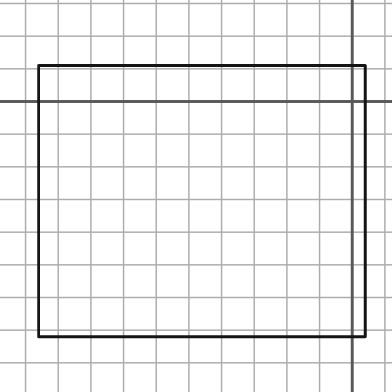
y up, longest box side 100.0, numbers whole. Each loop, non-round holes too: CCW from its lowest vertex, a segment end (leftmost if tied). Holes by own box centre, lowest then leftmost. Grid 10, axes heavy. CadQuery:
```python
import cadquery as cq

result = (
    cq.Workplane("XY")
    .moveTo(-96.0, -72.0)
    .lineTo(4.0, -72.0)
    .lineTo(4.0, 11.0)
    .lineTo(-96.0, 11.0)
    .close()
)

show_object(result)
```